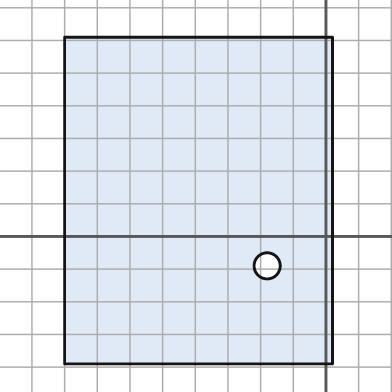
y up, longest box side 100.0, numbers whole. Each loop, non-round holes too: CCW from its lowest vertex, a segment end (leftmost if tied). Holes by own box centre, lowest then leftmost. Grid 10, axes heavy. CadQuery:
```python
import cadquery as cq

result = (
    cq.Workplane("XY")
    .moveTo(-80.0, -39.0)
    .lineTo(2.0, -39.0)
    .lineTo(2.0, 61.0)
    .lineTo(-80.0, 61.0)
    .close()
    .moveTo(-18.0, -9.0)
    .circle(4.0)
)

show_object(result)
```